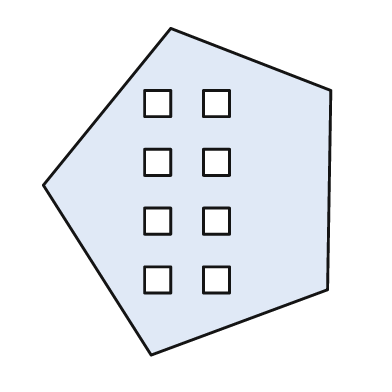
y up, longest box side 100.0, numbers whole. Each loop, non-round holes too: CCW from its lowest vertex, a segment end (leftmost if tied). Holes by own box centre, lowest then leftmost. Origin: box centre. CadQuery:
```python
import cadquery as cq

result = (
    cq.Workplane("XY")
    .moveTo(-11.0, -50.0)
    .lineTo(43.0, -30.0)
    .lineTo(44.0, 31.0)
    .lineTo(-5.0, 50.0)
    .lineTo(-44.0, 2.0)
    .close()
    .moveTo(-13.0, -31.0)
    .lineTo(-5.0, -31.0)
    .lineTo(-5.0, -23.0)
    .lineTo(-13.0, -23.0)
    .close()
    .moveTo(5.0, -31.0)
    .lineTo(13.0, -31.0)
    .lineTo(13.0, -23.0)
    .lineTo(5.0, -23.0)
    .close()
    .moveTo(-13.0, -13.0)
    .lineTo(-5.0, -13.0)
    .lineTo(-5.0, -5.0)
    .lineTo(-13.0, -5.0)
    .close()
    .moveTo(5.0, -13.0)
    .lineTo(13.0, -13.0)
    .lineTo(13.0, -5.0)
    .lineTo(5.0, -5.0)
    .close()
    .moveTo(-13.0, 5.0)
    .lineTo(-5.0, 5.0)
    .lineTo(-5.0, 13.0)
    .lineTo(-13.0, 13.0)
    .close()
    .moveTo(5.0, 5.0)
    .lineTo(13.0, 5.0)
    .lineTo(13.0, 13.0)
    .lineTo(5.0, 13.0)
    .close()
    .moveTo(-13.0, 23.0)
    .lineTo(-5.0, 23.0)
    .lineTo(-5.0, 31.0)
    .lineTo(-13.0, 31.0)
    .close()
    .moveTo(5.0, 23.0)
    .lineTo(13.0, 23.0)
    .lineTo(13.0, 31.0)
    .lineTo(5.0, 31.0)
    .close()
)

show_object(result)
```